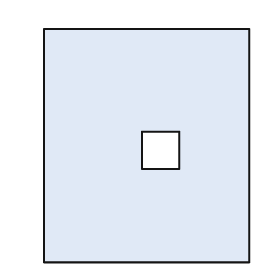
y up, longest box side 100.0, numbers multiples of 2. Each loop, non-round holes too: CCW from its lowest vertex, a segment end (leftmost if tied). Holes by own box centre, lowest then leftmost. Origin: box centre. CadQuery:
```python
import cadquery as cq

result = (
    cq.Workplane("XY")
    .moveTo(-44.0, -50.0)
    .lineTo(44.0, -50.0)
    .lineTo(44.0, 50.0)
    .lineTo(-44.0, 50.0)
    .close()
    .moveTo(-2.0, -10.0)
    .lineTo(14.0, -10.0)
    .lineTo(14.0, 6.0)
    .lineTo(-2.0, 6.0)
    .close()
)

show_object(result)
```